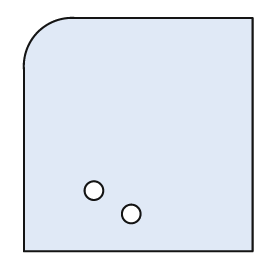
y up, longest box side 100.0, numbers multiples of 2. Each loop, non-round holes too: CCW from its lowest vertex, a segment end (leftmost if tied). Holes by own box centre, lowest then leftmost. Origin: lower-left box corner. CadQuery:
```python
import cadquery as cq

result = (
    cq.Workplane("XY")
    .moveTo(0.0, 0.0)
    .lineTo(98.0, 0.0)
    .lineTo(98.0, 100.0)
    .lineTo(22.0, 100.0)
    .threePointArc((6.0, 94.0), (0.0, 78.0))
    .close()
    .moveTo(46.0, 16.0)
    .circle(4.0)
    .moveTo(30.0, 26.0)
    .circle(4.0)
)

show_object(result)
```